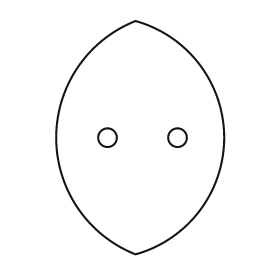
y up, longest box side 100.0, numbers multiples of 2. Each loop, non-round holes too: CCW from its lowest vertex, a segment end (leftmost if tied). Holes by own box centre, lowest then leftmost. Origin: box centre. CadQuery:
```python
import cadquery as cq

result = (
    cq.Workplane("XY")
    .moveTo(-2.0, -50.0)
    .threePointArc((36.0, 0.0), (-2.0, 50.0))
    .threePointArc((-36.0, 0.0), (-2.0, -50.0))
    .close()
    .moveTo(-14.0, 0.0)
    .circle(4.0)
    .moveTo(16.0, 0.0)
    .circle(4.0)
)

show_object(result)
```